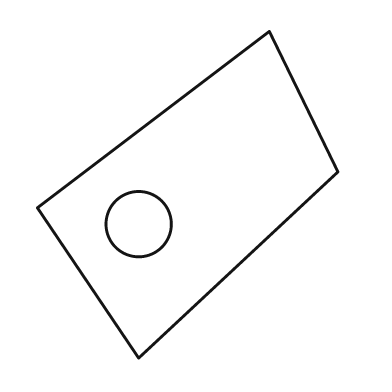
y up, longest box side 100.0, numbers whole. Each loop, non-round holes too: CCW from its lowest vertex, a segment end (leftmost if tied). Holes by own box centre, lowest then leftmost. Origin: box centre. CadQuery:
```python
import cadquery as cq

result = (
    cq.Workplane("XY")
    .moveTo(-15.0, -50.0)
    .lineTo(46.0, 7.0)
    .lineTo(25.0, 50.0)
    .lineTo(-46.0, -4.0)
    .close()
    .moveTo(-15.0, -9.0)
    .circle(10.0)
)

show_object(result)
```